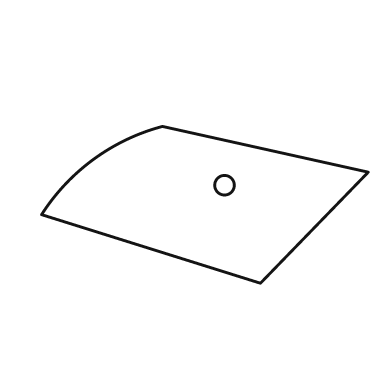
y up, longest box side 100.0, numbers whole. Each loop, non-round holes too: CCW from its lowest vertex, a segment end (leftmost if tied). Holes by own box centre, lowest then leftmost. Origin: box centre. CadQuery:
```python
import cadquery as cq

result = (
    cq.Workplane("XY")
    .moveTo(17.0, -24.0)
    .lineTo(50.0, 10.0)
    .lineTo(-13.0, 24.0)
    .threePointArc((-34.0, 14.0), (-50.0, -3.0))
    .close()
    .moveTo(6.0, 6.0)
    .circle(3.0)
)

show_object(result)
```